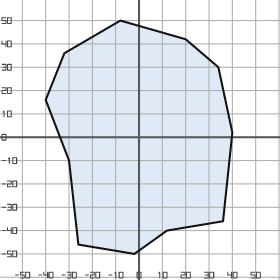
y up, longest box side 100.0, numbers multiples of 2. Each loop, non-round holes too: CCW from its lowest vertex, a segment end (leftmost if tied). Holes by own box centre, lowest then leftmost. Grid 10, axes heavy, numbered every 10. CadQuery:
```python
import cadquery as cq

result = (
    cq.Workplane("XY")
    .moveTo(-2.0, -50.0)
    .lineTo(12.0, -40.0)
    .lineTo(36.0, -36.0)
    .lineTo(40.0, 2.0)
    .lineTo(34.0, 30.0)
    .lineTo(20.0, 42.0)
    .lineTo(-8.0, 50.0)
    .lineTo(-32.0, 36.0)
    .lineTo(-40.0, 16.0)
    .lineTo(-30.0, -10.0)
    .lineTo(-26.0, -46.0)
    .close()
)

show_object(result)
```